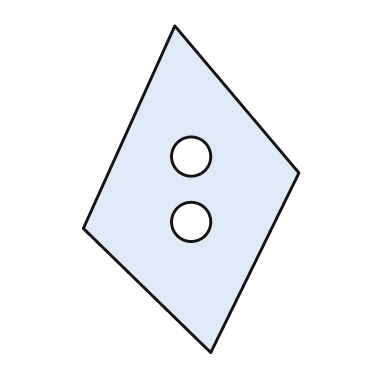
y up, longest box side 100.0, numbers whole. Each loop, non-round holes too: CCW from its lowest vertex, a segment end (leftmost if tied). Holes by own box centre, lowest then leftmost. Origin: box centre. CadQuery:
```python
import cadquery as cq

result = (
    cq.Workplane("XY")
    .moveTo(6.0, -50.0)
    .lineTo(33.0, 5.0)
    .lineTo(-5.0, 50.0)
    .lineTo(-33.0, -12.0)
    .close()
    .moveTo(0.0, -10.0)
    .circle(6.0)
    .moveTo(0.0, 10.0)
    .circle(6.0)
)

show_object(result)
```